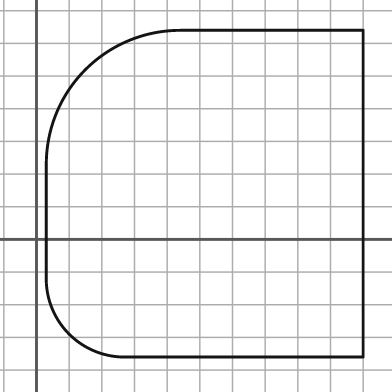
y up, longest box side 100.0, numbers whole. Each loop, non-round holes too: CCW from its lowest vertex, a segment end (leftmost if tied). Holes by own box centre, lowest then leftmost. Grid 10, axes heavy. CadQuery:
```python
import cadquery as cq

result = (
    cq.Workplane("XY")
    .moveTo(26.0, -36.0)
    .lineTo(100.0, -36.0)
    .lineTo(100.0, 64.0)
    .lineTo(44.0, 64.0)
    .threePointArc((15.0, 52.0), (3.0, 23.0))
    .lineTo(3.0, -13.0)
    .threePointArc((10.0, -29.0), (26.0, -36.0))
    .close()
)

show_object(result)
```